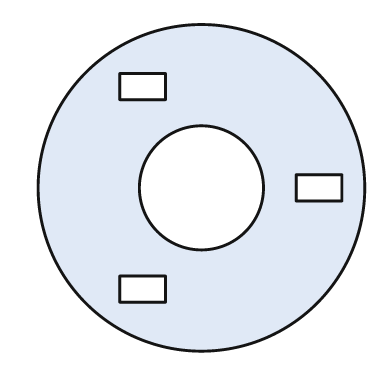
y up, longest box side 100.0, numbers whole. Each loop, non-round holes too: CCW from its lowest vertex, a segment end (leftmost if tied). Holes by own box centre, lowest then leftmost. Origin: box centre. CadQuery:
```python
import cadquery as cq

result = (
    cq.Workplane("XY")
    .moveTo(0.0, 0.0)
    .circle(50.0)
    .moveTo(-25.0, -35.0)
    .lineTo(-11.0, -35.0)
    .lineTo(-11.0, -27.0)
    .lineTo(-25.0, -27.0)
    .close()
    .moveTo(0.0, 0.0)
    .circle(19.0)
    .moveTo(29.0, -4.0)
    .lineTo(43.0, -4.0)
    .lineTo(43.0, 4.0)
    .lineTo(29.0, 4.0)
    .close()
    .moveTo(-25.0, 27.0)
    .lineTo(-11.0, 27.0)
    .lineTo(-11.0, 35.0)
    .lineTo(-25.0, 35.0)
    .close()
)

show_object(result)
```